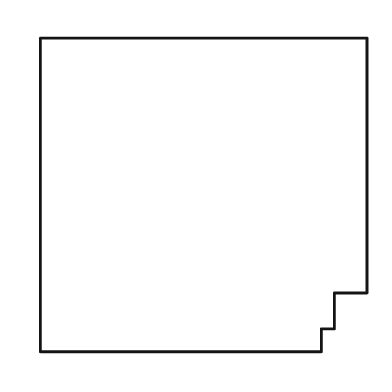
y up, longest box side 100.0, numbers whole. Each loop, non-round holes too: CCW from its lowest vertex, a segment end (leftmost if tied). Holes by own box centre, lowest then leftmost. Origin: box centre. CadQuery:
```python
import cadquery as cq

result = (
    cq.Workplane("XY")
    .moveTo(-50.0, -48.0)
    .lineTo(36.0, -48.0)
    .lineTo(36.0, -41.0)
    .lineTo(40.0, -41.0)
    .lineTo(40.0, -30.0)
    .lineTo(50.0, -30.0)
    .lineTo(50.0, 48.0)
    .lineTo(-50.0, 48.0)
    .close()
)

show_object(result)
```